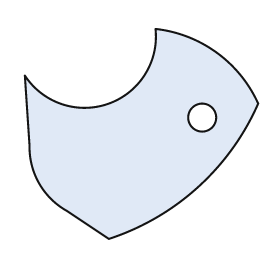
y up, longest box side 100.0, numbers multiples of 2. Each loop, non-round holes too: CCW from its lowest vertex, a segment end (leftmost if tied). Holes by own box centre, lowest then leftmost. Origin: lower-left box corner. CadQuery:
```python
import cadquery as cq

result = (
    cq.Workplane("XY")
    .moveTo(36.0, 0.0)
    .threePointArc((74.0, 22.0), (100.0, 58.0))
    .threePointArc((82.0, 80.0), (56.0, 90.0))
    .threePointArc((36.0, 58.0), (0.0, 70.0))
    .lineTo(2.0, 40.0)
    .threePointArc((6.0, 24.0), (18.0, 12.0))
    .close()
    .moveTo(76.0, 52.0)
    .circle(6.0)
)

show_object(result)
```